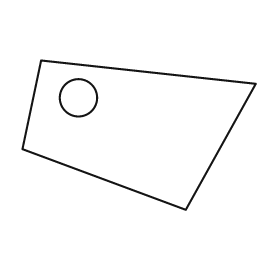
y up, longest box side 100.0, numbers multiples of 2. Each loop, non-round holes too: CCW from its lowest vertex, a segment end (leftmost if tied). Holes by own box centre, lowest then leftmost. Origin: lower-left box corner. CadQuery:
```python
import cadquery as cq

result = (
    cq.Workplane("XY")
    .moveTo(70.0, 0.0)
    .lineTo(100.0, 54.0)
    .lineTo(8.0, 64.0)
    .lineTo(0.0, 26.0)
    .close()
    .moveTo(24.0, 48.0)
    .circle(8.0)
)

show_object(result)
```